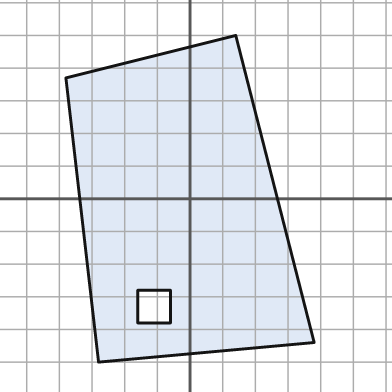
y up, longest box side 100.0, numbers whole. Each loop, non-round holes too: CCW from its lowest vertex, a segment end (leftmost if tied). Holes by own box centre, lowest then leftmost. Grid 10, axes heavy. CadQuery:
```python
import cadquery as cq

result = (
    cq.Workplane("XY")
    .moveTo(-28.0, -50.0)
    .lineTo(38.0, -44.0)
    .lineTo(14.0, 50.0)
    .lineTo(-38.0, 37.0)
    .close()
    .moveTo(-16.0, -38.0)
    .lineTo(-6.0, -38.0)
    .lineTo(-6.0, -28.0)
    .lineTo(-16.0, -28.0)
    .close()
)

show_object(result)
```